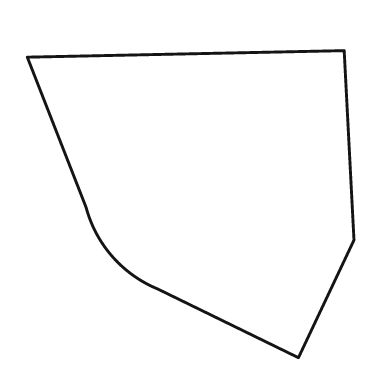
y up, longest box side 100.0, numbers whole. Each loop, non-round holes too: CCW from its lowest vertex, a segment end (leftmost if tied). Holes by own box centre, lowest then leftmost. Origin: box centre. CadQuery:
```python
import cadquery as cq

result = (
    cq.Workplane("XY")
    .moveTo(33.0, -47.0)
    .lineTo(50.0, -11.0)
    .lineTo(47.0, 47.0)
    .lineTo(-50.0, 45.0)
    .lineTo(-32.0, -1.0)
    .threePointArc((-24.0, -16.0), (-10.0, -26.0))
    .close()
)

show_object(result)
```